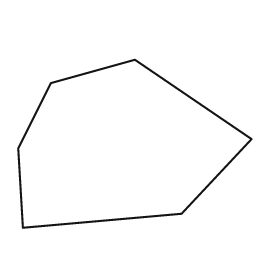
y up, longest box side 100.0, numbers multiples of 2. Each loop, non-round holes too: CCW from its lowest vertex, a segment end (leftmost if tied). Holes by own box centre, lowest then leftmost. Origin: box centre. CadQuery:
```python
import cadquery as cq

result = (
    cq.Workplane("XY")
    .moveTo(-48.0, -36.0)
    .lineTo(20.0, -30.0)
    .lineTo(50.0, 2.0)
    .lineTo(0.0, 36.0)
    .lineTo(-36.0, 26.0)
    .lineTo(-50.0, -2.0)
    .close()
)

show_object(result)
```